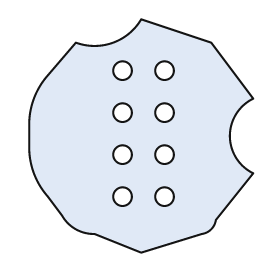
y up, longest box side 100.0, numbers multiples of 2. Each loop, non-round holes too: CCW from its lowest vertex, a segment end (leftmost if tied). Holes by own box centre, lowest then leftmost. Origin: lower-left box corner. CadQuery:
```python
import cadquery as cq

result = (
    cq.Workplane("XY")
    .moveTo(48.0, 0.0)
    .lineTo(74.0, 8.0)
    .threePointArc((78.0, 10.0), (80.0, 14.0))
    .lineTo(96.0, 34.0)
    .threePointArc((86.0, 50.0), (96.0, 66.0))
    .lineTo(78.0, 90.0)
    .lineTo(48.0, 100.0)
    .threePointArc((36.0, 90.0), (20.0, 90.0))
    .lineTo(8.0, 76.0)
    .threePointArc((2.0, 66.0), (0.0, 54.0))
    .lineTo(0.0, 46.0)
    .threePointArc((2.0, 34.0), (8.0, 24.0))
    .lineTo(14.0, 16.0)
    .threePointArc((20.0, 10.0), (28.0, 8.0))
    .close()
    .moveTo(40.0, 24.0)
    .circle(4.0)
    .moveTo(58.0, 24.0)
    .circle(4.0)
    .moveTo(40.0, 42.0)
    .circle(4.0)
    .moveTo(58.0, 42.0)
    .circle(4.0)
    .moveTo(40.0, 60.0)
    .circle(4.0)
    .moveTo(58.0, 60.0)
    .circle(4.0)
    .moveTo(40.0, 78.0)
    .circle(4.0)
    .moveTo(58.0, 78.0)
    .circle(4.0)
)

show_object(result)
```